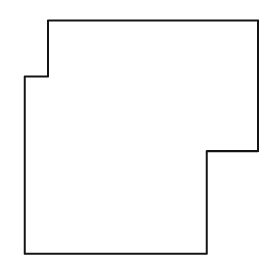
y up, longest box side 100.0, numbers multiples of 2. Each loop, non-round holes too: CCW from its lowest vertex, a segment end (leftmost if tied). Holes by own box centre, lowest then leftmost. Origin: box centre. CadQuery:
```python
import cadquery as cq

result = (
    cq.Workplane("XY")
    .moveTo(-50.0, -50.0)
    .lineTo(28.0, -50.0)
    .lineTo(28.0, -6.0)
    .lineTo(50.0, -6.0)
    .lineTo(50.0, 50.0)
    .lineTo(-40.0, 50.0)
    .lineTo(-40.0, 26.0)
    .lineTo(-50.0, 26.0)
    .close()
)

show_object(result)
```